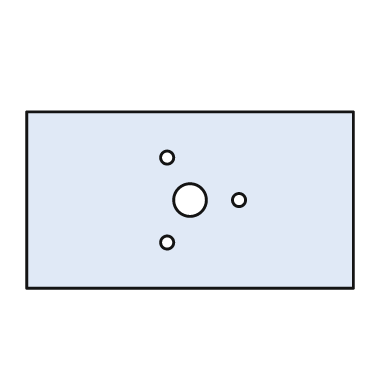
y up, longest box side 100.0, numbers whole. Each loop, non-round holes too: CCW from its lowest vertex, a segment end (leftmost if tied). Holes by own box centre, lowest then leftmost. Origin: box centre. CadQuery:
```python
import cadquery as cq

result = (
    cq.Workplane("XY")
    .moveTo(-50.0, -27.0)
    .lineTo(50.0, -27.0)
    .lineTo(50.0, 27.0)
    .lineTo(-50.0, 27.0)
    .close()
    .moveTo(-7.0, -13.0)
    .circle(2.0)
    .moveTo(0.0, 0.0)
    .circle(5.0)
    .moveTo(15.0, 0.0)
    .circle(2.0)
    .moveTo(-7.0, 13.0)
    .circle(2.0)
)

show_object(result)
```